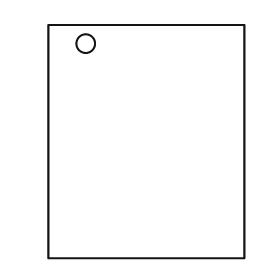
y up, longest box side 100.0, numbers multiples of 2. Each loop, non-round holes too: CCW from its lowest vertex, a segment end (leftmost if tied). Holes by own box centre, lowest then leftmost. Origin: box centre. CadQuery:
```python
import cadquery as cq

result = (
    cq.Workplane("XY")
    .moveTo(-42.0, -50.0)
    .lineTo(42.0, -50.0)
    .lineTo(42.0, 50.0)
    .lineTo(-42.0, 50.0)
    .close()
    .moveTo(-26.0, 42.0)
    .circle(4.0)
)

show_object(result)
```